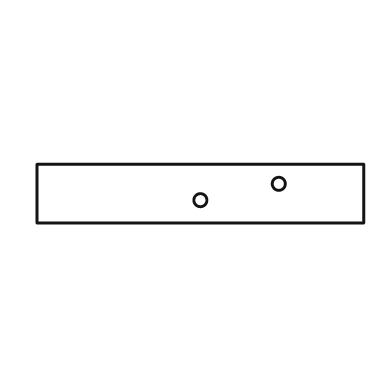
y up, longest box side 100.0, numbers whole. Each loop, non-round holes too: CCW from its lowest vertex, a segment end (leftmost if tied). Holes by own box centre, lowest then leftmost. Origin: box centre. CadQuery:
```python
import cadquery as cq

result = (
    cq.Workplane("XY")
    .moveTo(-50.0, -9.0)
    .lineTo(50.0, -9.0)
    .lineTo(50.0, 9.0)
    .lineTo(-50.0, 9.0)
    .close()
    .moveTo(0.0, -2.0)
    .circle(2.0)
    .moveTo(24.0, 3.0)
    .circle(2.0)
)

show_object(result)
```